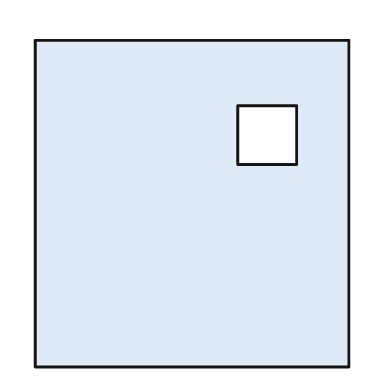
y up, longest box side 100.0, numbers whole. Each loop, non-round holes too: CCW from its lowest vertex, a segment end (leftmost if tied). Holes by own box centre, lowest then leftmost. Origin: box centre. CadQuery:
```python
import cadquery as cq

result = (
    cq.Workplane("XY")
    .moveTo(-48.0, -50.0)
    .lineTo(48.0, -50.0)
    .lineTo(48.0, 50.0)
    .lineTo(-48.0, 50.0)
    .close()
    .moveTo(14.0, 12.0)
    .lineTo(32.0, 12.0)
    .lineTo(32.0, 30.0)
    .lineTo(14.0, 30.0)
    .close()
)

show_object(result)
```